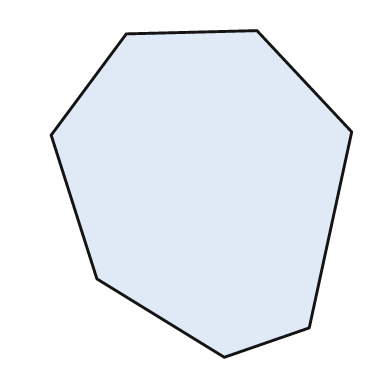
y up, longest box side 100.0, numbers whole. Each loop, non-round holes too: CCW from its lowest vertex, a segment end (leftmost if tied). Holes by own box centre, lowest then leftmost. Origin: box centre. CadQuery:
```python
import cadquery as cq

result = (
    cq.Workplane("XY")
    .moveTo(7.0, -50.0)
    .lineTo(33.0, -41.0)
    .lineTo(46.0, 19.0)
    .lineTo(17.0, 50.0)
    .lineTo(-23.0, 49.0)
    .lineTo(-46.0, 18.0)
    .lineTo(-32.0, -26.0)
    .close()
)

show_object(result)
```